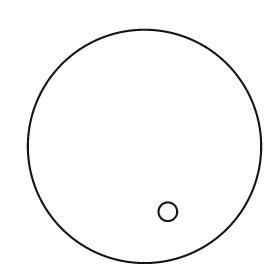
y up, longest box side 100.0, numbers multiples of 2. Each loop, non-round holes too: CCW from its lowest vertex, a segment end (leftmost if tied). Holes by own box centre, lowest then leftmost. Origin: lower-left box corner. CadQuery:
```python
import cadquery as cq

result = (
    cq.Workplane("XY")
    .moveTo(50.0, 50.0)
    .circle(50.0)
    .moveTo(60.0, 22.0)
    .circle(4.0)
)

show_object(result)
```